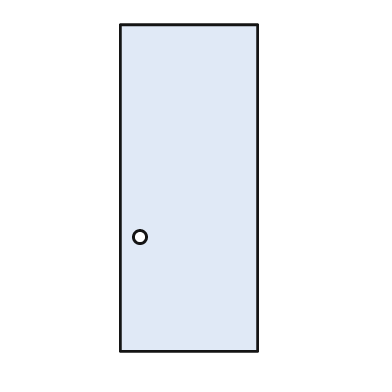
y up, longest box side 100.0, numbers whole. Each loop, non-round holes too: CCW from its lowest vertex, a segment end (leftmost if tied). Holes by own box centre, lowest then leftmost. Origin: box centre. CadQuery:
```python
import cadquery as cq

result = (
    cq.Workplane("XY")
    .moveTo(-21.0, -50.0)
    .lineTo(21.0, -50.0)
    .lineTo(21.0, 50.0)
    .lineTo(-21.0, 50.0)
    .close()
    .moveTo(-15.0, -15.0)
    .circle(2.0)
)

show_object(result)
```